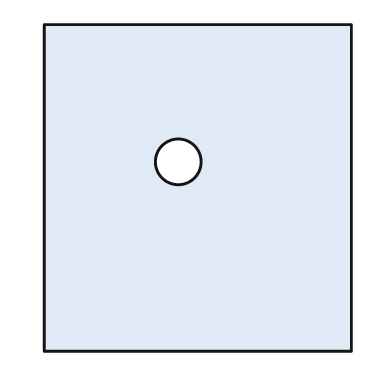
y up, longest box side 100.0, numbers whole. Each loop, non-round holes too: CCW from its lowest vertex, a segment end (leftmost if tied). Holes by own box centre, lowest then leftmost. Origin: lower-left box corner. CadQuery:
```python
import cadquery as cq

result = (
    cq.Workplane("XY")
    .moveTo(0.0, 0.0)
    .lineTo(94.0, 0.0)
    .lineTo(94.0, 100.0)
    .lineTo(0.0, 100.0)
    .close()
    .moveTo(41.0, 58.0)
    .circle(7.0)
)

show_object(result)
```